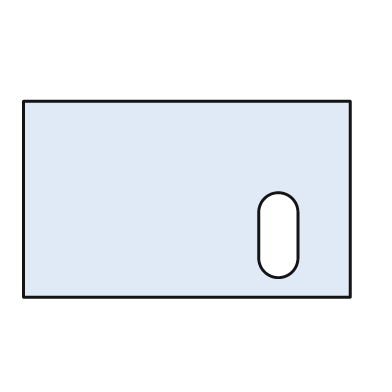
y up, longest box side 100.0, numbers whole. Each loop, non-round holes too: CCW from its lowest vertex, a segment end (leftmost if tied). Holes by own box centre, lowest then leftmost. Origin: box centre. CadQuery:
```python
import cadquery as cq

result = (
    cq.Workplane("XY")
    .moveTo(-50.0, -30.0)
    .lineTo(50.0, -30.0)
    .lineTo(50.0, 30.0)
    .lineTo(-50.0, 30.0)
    .close()
    .moveTo(22.0, -18.0)
    .threePointArc((28.0, -24.0), (34.0, -18.0))
    .lineTo(34.0, -4.0)
    .threePointArc((28.0, 2.0), (22.0, -4.0))
    .close()
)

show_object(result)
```